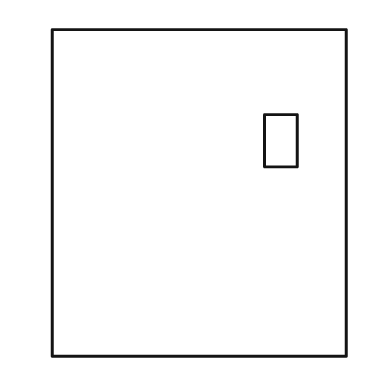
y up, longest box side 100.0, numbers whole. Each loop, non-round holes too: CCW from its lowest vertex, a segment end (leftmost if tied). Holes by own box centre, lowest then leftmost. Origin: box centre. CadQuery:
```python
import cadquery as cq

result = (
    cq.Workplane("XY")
    .moveTo(-45.0, -50.0)
    .lineTo(45.0, -50.0)
    .lineTo(45.0, 50.0)
    .lineTo(-45.0, 50.0)
    .close()
    .moveTo(20.0, 8.0)
    .lineTo(30.0, 8.0)
    .lineTo(30.0, 24.0)
    .lineTo(20.0, 24.0)
    .close()
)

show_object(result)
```